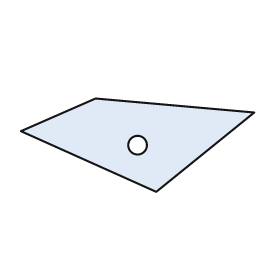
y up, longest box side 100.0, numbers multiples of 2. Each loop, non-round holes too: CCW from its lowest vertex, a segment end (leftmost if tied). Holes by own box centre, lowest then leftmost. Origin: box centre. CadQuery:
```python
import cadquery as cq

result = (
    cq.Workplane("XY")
    .moveTo(8.0, -20.0)
    .lineTo(50.0, 14.0)
    .lineTo(-18.0, 20.0)
    .lineTo(-50.0, 6.0)
    .close()
    .moveTo(0.0, 0.0)
    .circle(4.0)
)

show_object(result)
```